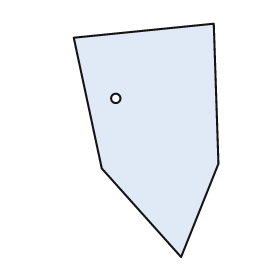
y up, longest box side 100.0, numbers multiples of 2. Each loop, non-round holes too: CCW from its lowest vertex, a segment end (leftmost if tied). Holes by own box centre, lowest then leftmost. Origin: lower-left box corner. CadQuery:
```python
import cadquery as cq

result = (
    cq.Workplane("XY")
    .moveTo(46.0, 0.0)
    .lineTo(62.0, 40.0)
    .lineTo(60.0, 100.0)
    .lineTo(0.0, 94.0)
    .lineTo(12.0, 38.0)
    .close()
    .moveTo(18.0, 68.0)
    .circle(2.0)
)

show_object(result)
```